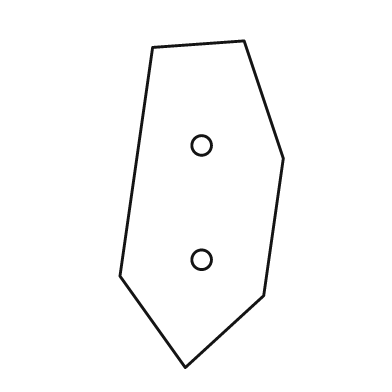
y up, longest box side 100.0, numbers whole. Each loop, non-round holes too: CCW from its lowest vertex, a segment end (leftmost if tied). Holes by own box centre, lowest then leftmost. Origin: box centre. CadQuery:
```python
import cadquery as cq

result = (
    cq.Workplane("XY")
    .moveTo(-5.0, -50.0)
    .lineTo(19.0, -28.0)
    .lineTo(25.0, 14.0)
    .lineTo(13.0, 50.0)
    .lineTo(-15.0, 48.0)
    .lineTo(-25.0, -22.0)
    .close()
    .moveTo(0.0, -17.0)
    .circle(3.0)
    .moveTo(0.0, 18.0)
    .circle(3.0)
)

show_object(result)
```